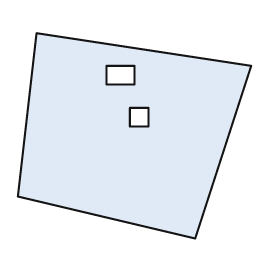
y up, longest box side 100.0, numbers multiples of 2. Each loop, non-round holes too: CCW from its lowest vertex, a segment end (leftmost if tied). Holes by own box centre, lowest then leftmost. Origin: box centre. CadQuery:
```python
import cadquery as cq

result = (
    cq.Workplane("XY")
    .moveTo(26.0, -44.0)
    .lineTo(50.0, 30.0)
    .lineTo(-42.0, 44.0)
    .lineTo(-50.0, -26.0)
    .close()
    .moveTo(-2.0, 4.0)
    .lineTo(6.0, 4.0)
    .lineTo(6.0, 12.0)
    .lineTo(-2.0, 12.0)
    .close()
    .moveTo(-12.0, 22.0)
    .lineTo(0.0, 22.0)
    .lineTo(0.0, 30.0)
    .lineTo(-12.0, 30.0)
    .close()
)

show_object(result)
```